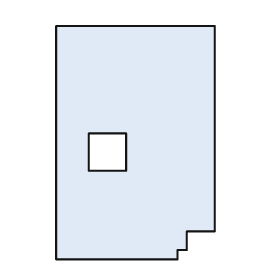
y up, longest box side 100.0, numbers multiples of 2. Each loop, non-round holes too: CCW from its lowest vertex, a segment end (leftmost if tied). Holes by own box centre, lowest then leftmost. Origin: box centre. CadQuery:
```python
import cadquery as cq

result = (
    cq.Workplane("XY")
    .moveTo(-34.0, -50.0)
    .lineTo(18.0, -50.0)
    .lineTo(18.0, -46.0)
    .lineTo(22.0, -46.0)
    .lineTo(22.0, -38.0)
    .lineTo(34.0, -38.0)
    .lineTo(34.0, 50.0)
    .lineTo(-34.0, 50.0)
    .close()
    .moveTo(-20.0, -12.0)
    .lineTo(-4.0, -12.0)
    .lineTo(-4.0, 4.0)
    .lineTo(-20.0, 4.0)
    .close()
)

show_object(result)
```